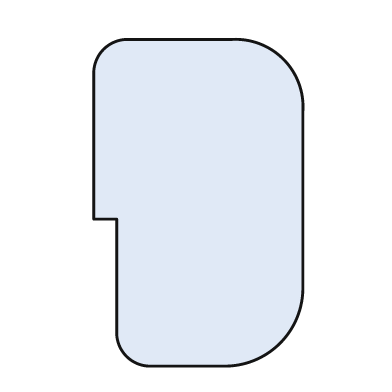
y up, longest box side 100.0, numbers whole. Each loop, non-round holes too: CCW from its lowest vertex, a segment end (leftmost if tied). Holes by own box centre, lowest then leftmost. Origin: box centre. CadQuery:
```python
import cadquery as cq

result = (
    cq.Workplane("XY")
    .moveTo(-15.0, -50.0)
    .lineTo(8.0, -50.0)
    .threePointArc((25.0, -43.0), (32.0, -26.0))
    .lineTo(32.0, 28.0)
    .threePointArc((26.0, 44.0), (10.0, 50.0))
    .lineTo(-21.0, 50.0)
    .threePointArc((-29.0, 47.0), (-32.0, 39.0))
    .lineTo(-32.0, -5.0)
    .lineTo(-25.0, -5.0)
    .lineTo(-25.0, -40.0)
    .threePointArc((-22.0, -47.0), (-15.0, -50.0))
    .close()
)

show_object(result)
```